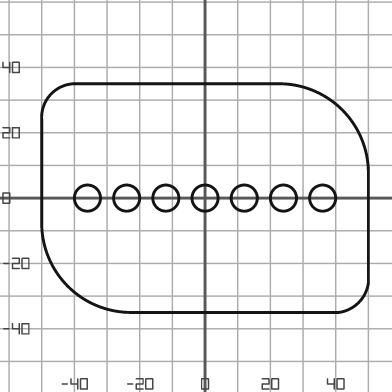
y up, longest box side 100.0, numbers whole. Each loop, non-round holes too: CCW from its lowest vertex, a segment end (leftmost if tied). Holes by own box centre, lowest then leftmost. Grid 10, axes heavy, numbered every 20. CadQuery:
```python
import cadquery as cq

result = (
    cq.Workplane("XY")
    .moveTo(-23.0, -35.0)
    .lineTo(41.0, -35.0)
    .threePointArc((47.0, -32.0), (50.0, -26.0))
    .lineTo(50.0, 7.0)
    .threePointArc((42.0, 27.0), (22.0, 35.0))
    .lineTo(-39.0, 35.0)
    .threePointArc((-47.0, 32.0), (-50.0, 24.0))
    .lineTo(-50.0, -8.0)
    .threePointArc((-42.0, -27.0), (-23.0, -35.0))
    .close()
    .moveTo(-36.0, 0.0)
    .circle(4.0)
    .moveTo(-24.0, 0.0)
    .circle(4.0)
    .moveTo(-12.0, 0.0)
    .circle(4.0)
    .moveTo(0.0, 0.0)
    .circle(4.0)
    .moveTo(12.0, 0.0)
    .circle(4.0)
    .moveTo(24.0, 0.0)
    .circle(4.0)
    .moveTo(36.0, 0.0)
    .circle(4.0)
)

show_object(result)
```